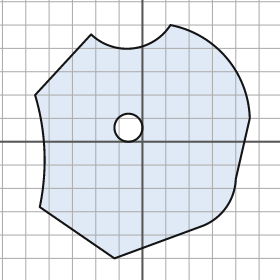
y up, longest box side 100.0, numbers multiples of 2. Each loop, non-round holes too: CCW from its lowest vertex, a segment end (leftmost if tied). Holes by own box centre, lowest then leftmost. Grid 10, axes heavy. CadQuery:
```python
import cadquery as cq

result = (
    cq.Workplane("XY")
    .moveTo(-12.0, -50.0)
    .lineTo(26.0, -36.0)
    .threePointArc((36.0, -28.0), (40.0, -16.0))
    .lineTo(46.0, 10.0)
    .threePointArc((36.0, 36.0), (12.0, 50.0))
    .threePointArc((-4.0, 40.0), (-22.0, 46.0))
    .lineTo(-46.0, 20.0)
    .threePointArc((-42.0, -4.0), (-44.0, -28.0))
    .close()
    .moveTo(-6.0, 6.0)
    .circle(6.0)
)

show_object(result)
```